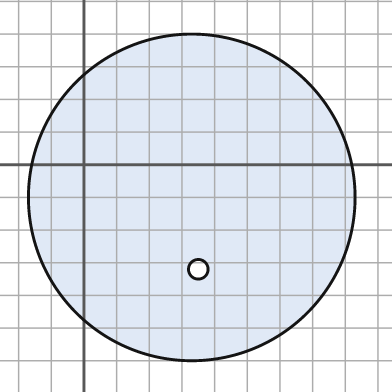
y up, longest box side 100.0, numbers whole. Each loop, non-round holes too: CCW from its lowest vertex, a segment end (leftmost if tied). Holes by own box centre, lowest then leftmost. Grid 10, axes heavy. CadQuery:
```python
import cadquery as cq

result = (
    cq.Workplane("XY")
    .moveTo(33.0, -10.0)
    .circle(50.0)
    .moveTo(35.0, -32.0)
    .circle(3.0)
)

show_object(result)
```